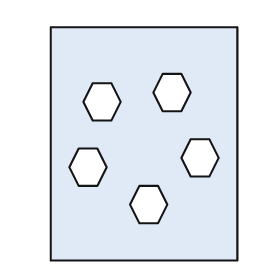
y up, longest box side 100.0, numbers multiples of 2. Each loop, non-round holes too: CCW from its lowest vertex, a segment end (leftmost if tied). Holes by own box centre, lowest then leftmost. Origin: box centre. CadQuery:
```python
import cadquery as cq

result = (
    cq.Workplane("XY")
    .moveTo(-40.0, -50.0)
    .lineTo(40.0, -50.0)
    .lineTo(40.0, 50.0)
    .lineTo(-40.0, 50.0)
    .close()
    .moveTo(-2.0, -34.0)
    .lineTo(6.0, -34.0)
    .lineTo(10.0, -26.0)
    .lineTo(6.0, -18.0)
    .lineTo(-2.0, -18.0)
    .lineTo(-6.0, -26.0)
    .close()
    .moveTo(-28.0, -18.0)
    .lineTo(-20.0, -18.0)
    .lineTo(-16.0, -10.0)
    .lineTo(-20.0, -2.0)
    .lineTo(-28.0, -2.0)
    .lineTo(-32.0, -10.0)
    .close()
    .moveTo(20.0, -14.0)
    .lineTo(28.0, -14.0)
    .lineTo(32.0, -6.0)
    .lineTo(28.0, 2.0)
    .lineTo(20.0, 2.0)
    .lineTo(16.0, -6.0)
    .close()
    .moveTo(-22.0, 10.0)
    .lineTo(-14.0, 10.0)
    .lineTo(-10.0, 18.0)
    .lineTo(-14.0, 26.0)
    .lineTo(-22.0, 26.0)
    .lineTo(-26.0, 18.0)
    .close()
    .moveTo(8.0, 14.0)
    .lineTo(16.0, 14.0)
    .lineTo(20.0, 22.0)
    .lineTo(16.0, 30.0)
    .lineTo(8.0, 30.0)
    .lineTo(4.0, 22.0)
    .close()
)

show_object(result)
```